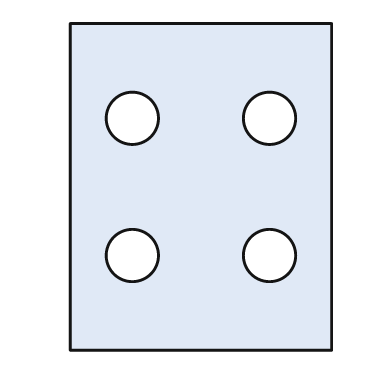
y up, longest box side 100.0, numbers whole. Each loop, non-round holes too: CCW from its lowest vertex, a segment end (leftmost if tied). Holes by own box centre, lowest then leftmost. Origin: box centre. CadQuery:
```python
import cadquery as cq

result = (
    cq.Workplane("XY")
    .moveTo(-40.0, -50.0)
    .lineTo(40.0, -50.0)
    .lineTo(40.0, 50.0)
    .lineTo(-40.0, 50.0)
    .close()
    .moveTo(-21.0, -21.0)
    .circle(8.0)
    .moveTo(21.0, -21.0)
    .circle(8.0)
    .moveTo(-21.0, 21.0)
    .circle(8.0)
    .moveTo(21.0, 21.0)
    .circle(8.0)
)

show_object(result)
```